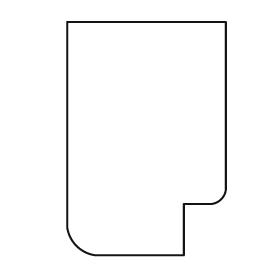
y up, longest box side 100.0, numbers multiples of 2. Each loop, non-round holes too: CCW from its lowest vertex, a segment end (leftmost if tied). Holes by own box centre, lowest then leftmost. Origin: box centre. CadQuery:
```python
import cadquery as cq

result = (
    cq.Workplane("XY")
    .moveTo(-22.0, -50.0)
    .lineTo(16.0, -50.0)
    .lineTo(16.0, -28.0)
    .lineTo(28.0, -28.0)
    .threePointArc((32.0, -26.0), (34.0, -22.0))
    .lineTo(34.0, 50.0)
    .lineTo(-34.0, 50.0)
    .lineTo(-34.0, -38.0)
    .threePointArc((-30.0, -46.0), (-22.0, -50.0))
    .close()
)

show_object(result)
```